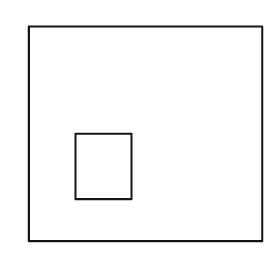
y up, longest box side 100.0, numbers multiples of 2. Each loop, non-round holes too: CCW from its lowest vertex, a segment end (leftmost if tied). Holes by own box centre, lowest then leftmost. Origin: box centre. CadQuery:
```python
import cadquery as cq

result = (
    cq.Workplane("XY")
    .moveTo(-50.0, -46.0)
    .lineTo(50.0, -46.0)
    .lineTo(50.0, 46.0)
    .lineTo(-50.0, 46.0)
    .close()
    .moveTo(-30.0, -28.0)
    .lineTo(-6.0, -28.0)
    .lineTo(-6.0, 0.0)
    .lineTo(-30.0, 0.0)
    .close()
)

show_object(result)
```